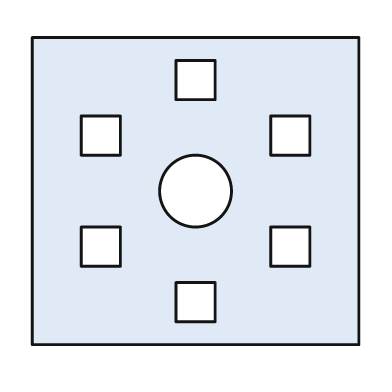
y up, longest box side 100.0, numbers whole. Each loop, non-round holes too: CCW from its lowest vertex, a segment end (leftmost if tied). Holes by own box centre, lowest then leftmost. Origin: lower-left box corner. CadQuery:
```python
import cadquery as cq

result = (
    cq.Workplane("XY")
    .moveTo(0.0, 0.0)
    .lineTo(100.0, 0.0)
    .lineTo(100.0, 94.0)
    .lineTo(0.0, 94.0)
    .close()
    .moveTo(44.0, 7.0)
    .lineTo(56.0, 7.0)
    .lineTo(56.0, 19.0)
    .lineTo(44.0, 19.0)
    .close()
    .moveTo(15.0, 24.0)
    .lineTo(27.0, 24.0)
    .lineTo(27.0, 36.0)
    .lineTo(15.0, 36.0)
    .close()
    .moveTo(73.0, 24.0)
    .lineTo(85.0, 24.0)
    .lineTo(85.0, 36.0)
    .lineTo(73.0, 36.0)
    .close()
    .moveTo(50.0, 47.0)
    .circle(11.0)
    .moveTo(15.0, 58.0)
    .lineTo(27.0, 58.0)
    .lineTo(27.0, 70.0)
    .lineTo(15.0, 70.0)
    .close()
    .moveTo(73.0, 58.0)
    .lineTo(85.0, 58.0)
    .lineTo(85.0, 70.0)
    .lineTo(73.0, 70.0)
    .close()
    .moveTo(44.0, 75.0)
    .lineTo(56.0, 75.0)
    .lineTo(56.0, 87.0)
    .lineTo(44.0, 87.0)
    .close()
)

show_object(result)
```